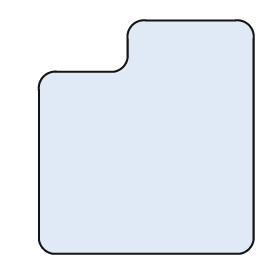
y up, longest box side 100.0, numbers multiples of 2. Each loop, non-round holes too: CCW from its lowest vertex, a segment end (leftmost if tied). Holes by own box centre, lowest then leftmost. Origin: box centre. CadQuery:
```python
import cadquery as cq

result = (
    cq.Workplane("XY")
    .moveTo(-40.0, -50.0)
    .lineTo(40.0, -50.0)
    .threePointArc((44.0, -48.0), (46.0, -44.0))
    .lineTo(46.0, 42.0)
    .threePointArc((44.0, 48.0), (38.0, 50.0))
    .lineTo(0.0, 50.0)
    .threePointArc((-6.0, 48.0), (-8.0, 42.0))
    .lineTo(-8.0, 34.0)
    .threePointArc((-10.0, 30.0), (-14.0, 28.0))
    .lineTo(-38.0, 28.0)
    .threePointArc((-44.0, 26.0), (-46.0, 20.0))
    .lineTo(-46.0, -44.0)
    .threePointArc((-44.0, -48.0), (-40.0, -50.0))
    .close()
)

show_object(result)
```